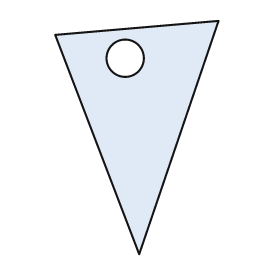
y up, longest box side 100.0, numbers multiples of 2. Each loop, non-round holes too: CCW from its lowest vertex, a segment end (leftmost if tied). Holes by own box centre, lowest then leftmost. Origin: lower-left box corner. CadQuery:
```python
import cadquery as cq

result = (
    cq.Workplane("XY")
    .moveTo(36.0, 0.0)
    .lineTo(70.0, 100.0)
    .lineTo(0.0, 94.0)
    .close()
    .moveTo(30.0, 84.0)
    .circle(8.0)
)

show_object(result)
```